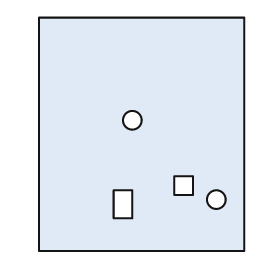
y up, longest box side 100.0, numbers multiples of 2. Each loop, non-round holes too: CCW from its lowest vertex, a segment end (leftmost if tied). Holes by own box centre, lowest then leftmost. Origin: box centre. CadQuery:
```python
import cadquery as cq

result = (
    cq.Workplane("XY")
    .moveTo(-44.0, -50.0)
    .lineTo(44.0, -50.0)
    .lineTo(44.0, 50.0)
    .lineTo(-44.0, 50.0)
    .close()
    .moveTo(-12.0, -36.0)
    .lineTo(-4.0, -36.0)
    .lineTo(-4.0, -24.0)
    .lineTo(-12.0, -24.0)
    .close()
    .moveTo(32.0, -28.0)
    .circle(4.0)
    .moveTo(14.0, -26.0)
    .lineTo(22.0, -26.0)
    .lineTo(22.0, -18.0)
    .lineTo(14.0, -18.0)
    .close()
    .moveTo(-4.0, 6.0)
    .circle(4.0)
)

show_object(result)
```